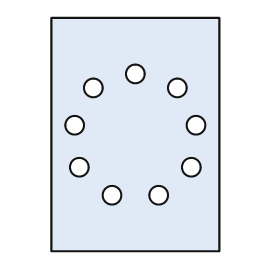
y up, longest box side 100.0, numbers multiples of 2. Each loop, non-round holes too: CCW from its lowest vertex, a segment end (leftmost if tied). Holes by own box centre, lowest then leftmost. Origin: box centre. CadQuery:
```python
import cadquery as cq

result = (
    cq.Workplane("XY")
    .moveTo(-36.0, -50.0)
    .lineTo(36.0, -50.0)
    .lineTo(36.0, 50.0)
    .lineTo(-36.0, 50.0)
    .close()
    .moveTo(-10.0, -26.0)
    .circle(4.0)
    .moveTo(10.0, -26.0)
    .circle(4.0)
    .moveTo(-24.0, -14.0)
    .circle(4.0)
    .moveTo(24.0, -14.0)
    .circle(4.0)
    .moveTo(-26.0, 4.0)
    .circle(4.0)
    .moveTo(26.0, 4.0)
    .circle(4.0)
    .moveTo(-18.0, 20.0)
    .circle(4.0)
    .moveTo(18.0, 20.0)
    .circle(4.0)
    .moveTo(0.0, 26.0)
    .circle(4.0)
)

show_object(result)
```